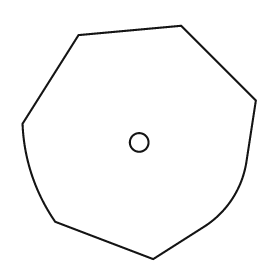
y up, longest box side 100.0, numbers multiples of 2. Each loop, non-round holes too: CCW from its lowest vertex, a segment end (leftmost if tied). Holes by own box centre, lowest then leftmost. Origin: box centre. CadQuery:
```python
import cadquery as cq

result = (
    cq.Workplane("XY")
    .moveTo(6.0, -50.0)
    .lineTo(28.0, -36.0)
    .threePointArc((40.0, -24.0), (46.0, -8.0))
    .lineTo(50.0, 18.0)
    .lineTo(18.0, 50.0)
    .lineTo(-26.0, 46.0)
    .lineTo(-50.0, 8.0)
    .threePointArc((-46.0, -14.0), (-36.0, -34.0))
    .close()
    .moveTo(0.0, 0.0)
    .circle(4.0)
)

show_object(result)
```